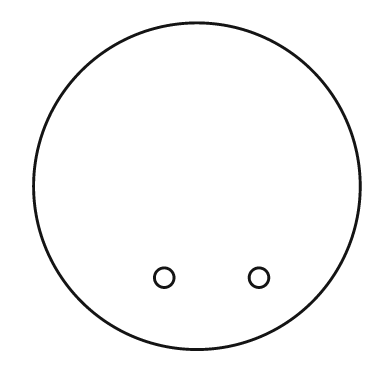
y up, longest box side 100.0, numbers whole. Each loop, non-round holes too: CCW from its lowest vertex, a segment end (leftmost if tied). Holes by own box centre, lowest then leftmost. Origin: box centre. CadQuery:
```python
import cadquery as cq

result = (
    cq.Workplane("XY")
    .moveTo(0.0, 0.0)
    .circle(50.0)
    .moveTo(-10.0, -28.0)
    .circle(3.0)
    .moveTo(19.0, -28.0)
    .circle(3.0)
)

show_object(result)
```